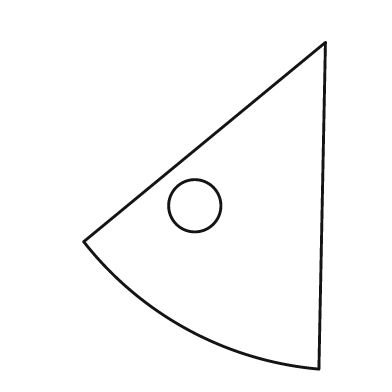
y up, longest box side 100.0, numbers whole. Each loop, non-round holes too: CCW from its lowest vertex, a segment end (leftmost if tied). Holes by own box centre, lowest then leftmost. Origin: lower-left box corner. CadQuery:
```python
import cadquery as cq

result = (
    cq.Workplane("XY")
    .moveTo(72.0, 0.0)
    .lineTo(74.0, 100.0)
    .lineTo(0.0, 39.0)
    .threePointArc((32.0, 12.0), (72.0, 0.0))
    .close()
    .moveTo(34.0, 50.0)
    .circle(8.0)
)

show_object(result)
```